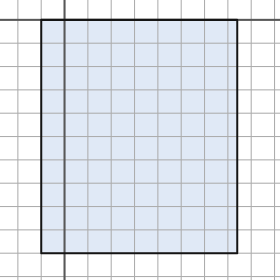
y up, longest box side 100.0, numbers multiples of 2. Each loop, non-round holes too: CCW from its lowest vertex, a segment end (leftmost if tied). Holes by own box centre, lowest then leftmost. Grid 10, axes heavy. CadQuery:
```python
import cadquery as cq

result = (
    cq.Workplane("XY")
    .moveTo(-10.0, -100.0)
    .lineTo(74.0, -100.0)
    .lineTo(74.0, 0.0)
    .lineTo(-10.0, 0.0)
    .close()
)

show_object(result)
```